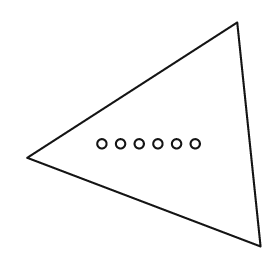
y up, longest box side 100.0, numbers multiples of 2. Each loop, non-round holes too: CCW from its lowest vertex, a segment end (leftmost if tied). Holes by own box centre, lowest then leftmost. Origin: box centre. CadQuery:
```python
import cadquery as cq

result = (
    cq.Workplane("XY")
    .moveTo(50.0, -48.0)
    .lineTo(40.0, 48.0)
    .lineTo(-50.0, -10.0)
    .close()
    .moveTo(-18.0, -4.0)
    .circle(2.0)
    .moveTo(-10.0, -4.0)
    .circle(2.0)
    .moveTo(-2.0, -4.0)
    .circle(2.0)
    .moveTo(6.0, -4.0)
    .circle(2.0)
    .moveTo(14.0, -4.0)
    .circle(2.0)
    .moveTo(22.0, -4.0)
    .circle(2.0)
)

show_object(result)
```